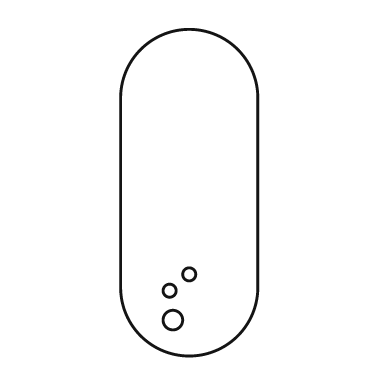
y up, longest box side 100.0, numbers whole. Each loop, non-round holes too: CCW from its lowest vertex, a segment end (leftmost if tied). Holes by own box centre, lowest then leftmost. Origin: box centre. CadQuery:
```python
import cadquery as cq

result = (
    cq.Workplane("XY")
    .moveTo(-21.0, -29.0)
    .threePointArc((0.0, -50.0), (21.0, -29.0))
    .lineTo(21.0, 29.0)
    .threePointArc((0.0, 50.0), (-21.0, 29.0))
    .close()
    .moveTo(-5.0, -39.0)
    .circle(3.0)
    .moveTo(-6.0, -30.0)
    .circle(2.0)
    .moveTo(0.0, -25.0)
    .circle(2.0)
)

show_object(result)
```